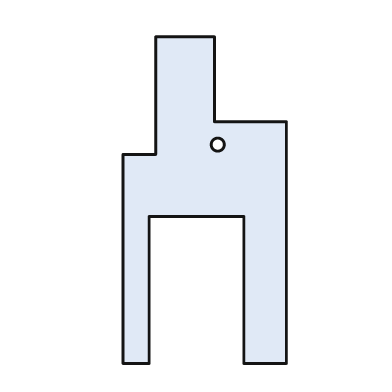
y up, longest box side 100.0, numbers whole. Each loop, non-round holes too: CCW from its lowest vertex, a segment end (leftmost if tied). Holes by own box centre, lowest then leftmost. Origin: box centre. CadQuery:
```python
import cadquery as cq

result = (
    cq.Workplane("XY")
    .moveTo(-25.0, -50.0)
    .lineTo(-17.0, -50.0)
    .lineTo(-17.0, -5.0)
    .lineTo(12.0, -5.0)
    .lineTo(12.0, -50.0)
    .lineTo(25.0, -50.0)
    .lineTo(25.0, 24.0)
    .lineTo(3.0, 24.0)
    .lineTo(3.0, 50.0)
    .lineTo(-15.0, 50.0)
    .lineTo(-15.0, 14.0)
    .lineTo(-25.0, 14.0)
    .close()
    .moveTo(4.0, 17.0)
    .circle(2.0)
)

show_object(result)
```